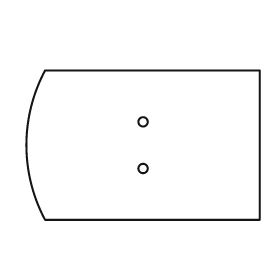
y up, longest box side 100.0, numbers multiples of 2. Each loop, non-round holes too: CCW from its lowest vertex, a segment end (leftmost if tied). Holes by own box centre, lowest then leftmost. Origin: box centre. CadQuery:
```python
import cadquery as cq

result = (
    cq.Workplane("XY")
    .moveTo(-42.0, -32.0)
    .lineTo(50.0, -32.0)
    .lineTo(50.0, 32.0)
    .lineTo(-42.0, 32.0)
    .threePointArc((-50.0, 0.0), (-42.0, -32.0))
    .close()
    .moveTo(0.0, -10.0)
    .circle(2.0)
    .moveTo(0.0, 10.0)
    .circle(2.0)
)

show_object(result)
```